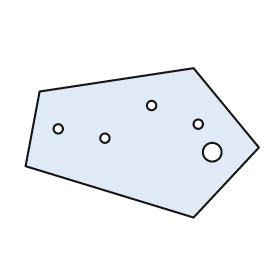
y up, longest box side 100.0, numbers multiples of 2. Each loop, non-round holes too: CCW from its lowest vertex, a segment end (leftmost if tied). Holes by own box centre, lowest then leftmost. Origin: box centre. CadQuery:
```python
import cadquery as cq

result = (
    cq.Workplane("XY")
    .moveTo(22.0, -32.0)
    .lineTo(50.0, -2.0)
    .lineTo(22.0, 32.0)
    .lineTo(-44.0, 22.0)
    .lineTo(-50.0, -10.0)
    .close()
    .moveTo(30.0, -4.0)
    .circle(4.0)
    .moveTo(-16.0, 2.0)
    .circle(2.0)
    .moveTo(-36.0, 6.0)
    .circle(2.0)
    .moveTo(24.0, 8.0)
    .circle(2.0)
    .moveTo(4.0, 16.0)
    .circle(2.0)
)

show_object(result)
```